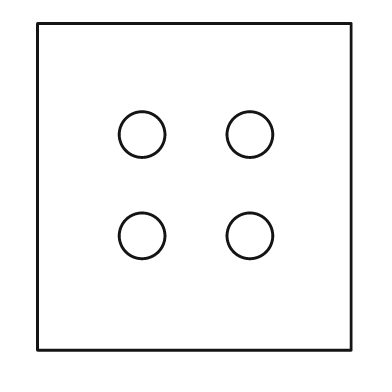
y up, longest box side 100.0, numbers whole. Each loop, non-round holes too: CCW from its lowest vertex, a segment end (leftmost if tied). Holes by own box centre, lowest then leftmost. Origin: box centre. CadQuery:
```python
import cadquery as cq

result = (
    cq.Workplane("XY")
    .moveTo(-48.0, -50.0)
    .lineTo(48.0, -50.0)
    .lineTo(48.0, 50.0)
    .lineTo(-48.0, 50.0)
    .close()
    .moveTo(-16.0, -15.0)
    .circle(7.0)
    .moveTo(17.0, -15.0)
    .circle(7.0)
    .moveTo(-16.0, 16.0)
    .circle(7.0)
    .moveTo(17.0, 16.0)
    .circle(7.0)
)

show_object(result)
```